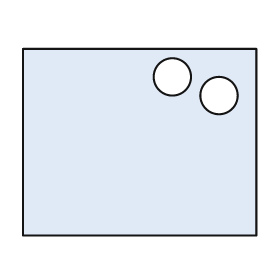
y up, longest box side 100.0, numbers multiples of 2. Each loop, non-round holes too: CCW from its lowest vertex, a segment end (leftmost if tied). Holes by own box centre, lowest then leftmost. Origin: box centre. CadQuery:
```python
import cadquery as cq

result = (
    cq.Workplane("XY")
    .moveTo(-50.0, -40.0)
    .lineTo(50.0, -40.0)
    .lineTo(50.0, 40.0)
    .lineTo(-50.0, 40.0)
    .close()
    .moveTo(34.0, 20.0)
    .circle(8.0)
    .moveTo(14.0, 28.0)
    .circle(8.0)
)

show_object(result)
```